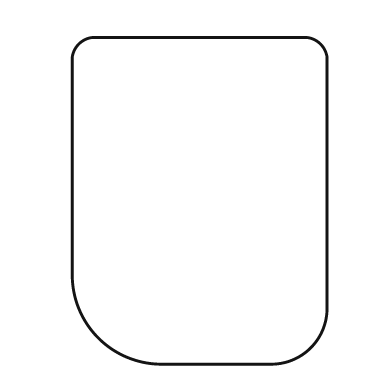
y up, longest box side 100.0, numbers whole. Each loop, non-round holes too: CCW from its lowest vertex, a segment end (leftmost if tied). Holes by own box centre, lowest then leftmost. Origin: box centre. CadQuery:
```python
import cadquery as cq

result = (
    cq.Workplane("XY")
    .moveTo(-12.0, -50.0)
    .lineTo(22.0, -50.0)
    .threePointArc((34.0, -45.0), (39.0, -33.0))
    .lineTo(39.0, 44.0)
    .threePointArc((37.0, 48.0), (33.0, 50.0))
    .lineTo(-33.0, 50.0)
    .threePointArc((-37.0, 48.0), (-39.0, 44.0))
    .lineTo(-39.0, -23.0)
    .threePointArc((-31.0, -42.0), (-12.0, -50.0))
    .close()
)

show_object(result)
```